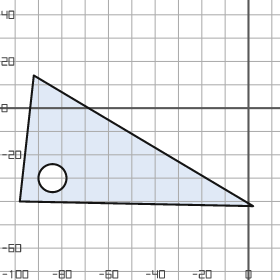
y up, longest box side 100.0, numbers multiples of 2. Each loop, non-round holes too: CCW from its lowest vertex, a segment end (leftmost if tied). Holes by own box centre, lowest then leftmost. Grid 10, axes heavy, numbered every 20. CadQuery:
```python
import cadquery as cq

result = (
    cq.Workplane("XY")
    .moveTo(2.0, -42.0)
    .lineTo(-92.0, 14.0)
    .lineTo(-98.0, -40.0)
    .close()
    .moveTo(-84.0, -30.0)
    .circle(6.0)
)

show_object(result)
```